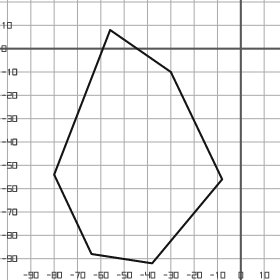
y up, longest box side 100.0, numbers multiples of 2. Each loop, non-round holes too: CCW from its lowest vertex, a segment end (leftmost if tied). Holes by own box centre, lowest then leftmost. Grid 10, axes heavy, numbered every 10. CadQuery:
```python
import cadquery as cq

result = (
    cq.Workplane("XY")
    .moveTo(-38.0, -92.0)
    .lineTo(-8.0, -56.0)
    .lineTo(-30.0, -10.0)
    .lineTo(-56.0, 8.0)
    .lineTo(-80.0, -54.0)
    .lineTo(-64.0, -88.0)
    .close()
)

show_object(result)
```